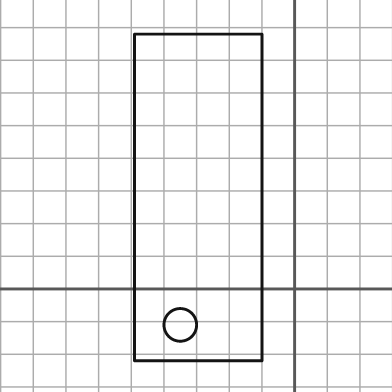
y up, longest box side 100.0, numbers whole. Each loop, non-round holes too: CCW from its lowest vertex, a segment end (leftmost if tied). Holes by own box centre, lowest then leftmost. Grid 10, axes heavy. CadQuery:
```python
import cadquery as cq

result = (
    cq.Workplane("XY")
    .moveTo(-49.0, -22.0)
    .lineTo(-10.0, -22.0)
    .lineTo(-10.0, 78.0)
    .lineTo(-49.0, 78.0)
    .close()
    .moveTo(-35.0, -11.0)
    .circle(5.0)
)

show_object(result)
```